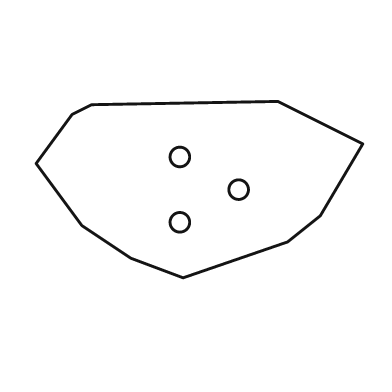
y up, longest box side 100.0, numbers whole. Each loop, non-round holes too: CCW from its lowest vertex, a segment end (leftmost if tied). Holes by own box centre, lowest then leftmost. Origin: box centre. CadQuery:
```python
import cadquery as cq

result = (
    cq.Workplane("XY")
    .moveTo(-5.0, -27.0)
    .lineTo(27.0, -16.0)
    .lineTo(37.0, -8.0)
    .lineTo(50.0, 14.0)
    .lineTo(24.0, 27.0)
    .lineTo(-33.0, 26.0)
    .lineTo(-39.0, 23.0)
    .lineTo(-50.0, 8.0)
    .lineTo(-36.0, -11.0)
    .lineTo(-21.0, -21.0)
    .close()
    .moveTo(-6.0, -10.0)
    .circle(3.0)
    .moveTo(12.0, 0.0)
    .circle(3.0)
    .moveTo(-6.0, 10.0)
    .circle(3.0)
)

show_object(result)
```